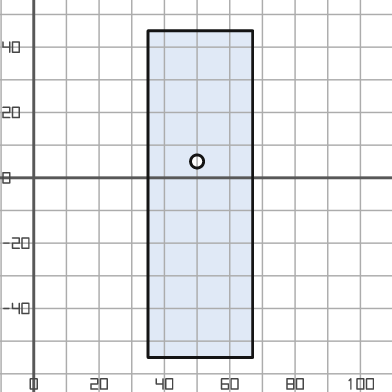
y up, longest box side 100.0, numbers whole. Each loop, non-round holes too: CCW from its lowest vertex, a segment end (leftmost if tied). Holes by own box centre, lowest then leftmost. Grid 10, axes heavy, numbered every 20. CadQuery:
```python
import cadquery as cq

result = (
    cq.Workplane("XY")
    .moveTo(35.0, -55.0)
    .lineTo(67.0, -55.0)
    .lineTo(67.0, 45.0)
    .lineTo(35.0, 45.0)
    .close()
    .moveTo(50.0, 5.0)
    .circle(2.0)
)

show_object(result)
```